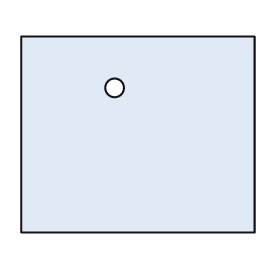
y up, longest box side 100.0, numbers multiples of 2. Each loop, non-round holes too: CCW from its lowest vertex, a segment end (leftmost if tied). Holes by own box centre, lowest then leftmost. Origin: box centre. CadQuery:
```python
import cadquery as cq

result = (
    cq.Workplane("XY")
    .moveTo(-50.0, -42.0)
    .lineTo(50.0, -42.0)
    .lineTo(50.0, 42.0)
    .lineTo(-50.0, 42.0)
    .close()
    .moveTo(-10.0, 20.0)
    .circle(4.0)
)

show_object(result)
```